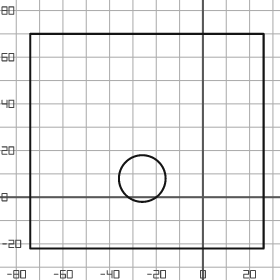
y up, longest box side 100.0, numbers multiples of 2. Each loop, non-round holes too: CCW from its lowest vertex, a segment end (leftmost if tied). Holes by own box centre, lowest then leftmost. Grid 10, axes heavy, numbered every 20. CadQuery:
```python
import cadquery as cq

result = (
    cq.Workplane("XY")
    .moveTo(-74.0, -22.0)
    .lineTo(26.0, -22.0)
    .lineTo(26.0, 70.0)
    .lineTo(-74.0, 70.0)
    .close()
    .moveTo(-26.0, 8.0)
    .circle(10.0)
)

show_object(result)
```